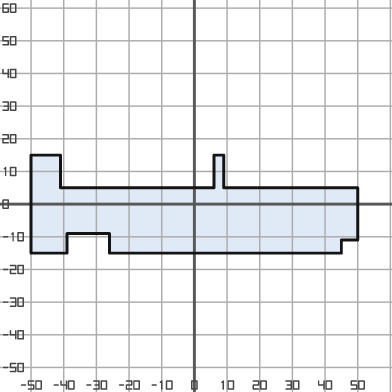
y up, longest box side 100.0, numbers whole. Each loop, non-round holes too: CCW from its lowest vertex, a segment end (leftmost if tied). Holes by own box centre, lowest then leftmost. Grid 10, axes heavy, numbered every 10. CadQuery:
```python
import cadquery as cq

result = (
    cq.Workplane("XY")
    .moveTo(-50.0, -15.0)
    .lineTo(-39.0, -15.0)
    .lineTo(-39.0, -9.0)
    .lineTo(-26.0, -9.0)
    .lineTo(-26.0, -15.0)
    .lineTo(45.0, -15.0)
    .lineTo(45.0, -11.0)
    .lineTo(50.0, -11.0)
    .lineTo(50.0, 5.0)
    .lineTo(9.0, 5.0)
    .lineTo(9.0, 15.0)
    .lineTo(6.0, 15.0)
    .lineTo(6.0, 5.0)
    .lineTo(-41.0, 5.0)
    .lineTo(-41.0, 15.0)
    .lineTo(-50.0, 15.0)
    .close()
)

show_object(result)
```